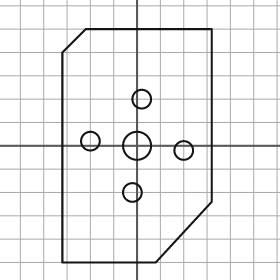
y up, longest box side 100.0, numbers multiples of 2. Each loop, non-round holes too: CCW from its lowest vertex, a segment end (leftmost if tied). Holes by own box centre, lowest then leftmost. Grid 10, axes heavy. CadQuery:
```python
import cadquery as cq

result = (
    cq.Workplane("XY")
    .moveTo(-32.0, -50.0)
    .lineTo(8.0, -50.0)
    .lineTo(32.0, -24.0)
    .lineTo(32.0, 50.0)
    .lineTo(-22.0, 50.0)
    .lineTo(-32.0, 40.0)
    .close()
    .moveTo(-2.0, -20.0)
    .circle(4.0)
    .moveTo(20.0, -2.0)
    .circle(4.0)
    .moveTo(0.0, 0.0)
    .circle(6.0)
    .moveTo(-20.0, 2.0)
    .circle(4.0)
    .moveTo(2.0, 20.0)
    .circle(4.0)
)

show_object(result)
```